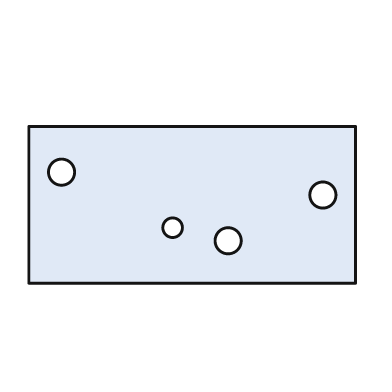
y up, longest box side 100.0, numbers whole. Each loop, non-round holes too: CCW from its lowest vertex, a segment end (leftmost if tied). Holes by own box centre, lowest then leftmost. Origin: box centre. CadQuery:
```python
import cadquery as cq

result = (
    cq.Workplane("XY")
    .moveTo(-50.0, -24.0)
    .lineTo(50.0, -24.0)
    .lineTo(50.0, 24.0)
    .lineTo(-50.0, 24.0)
    .close()
    .moveTo(11.0, -11.0)
    .circle(4.0)
    .moveTo(-6.0, -7.0)
    .circle(3.0)
    .moveTo(40.0, 3.0)
    .circle(4.0)
    .moveTo(-40.0, 10.0)
    .circle(4.0)
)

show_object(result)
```